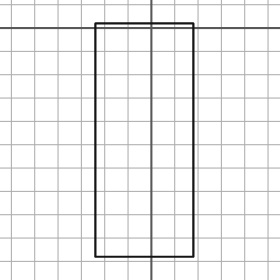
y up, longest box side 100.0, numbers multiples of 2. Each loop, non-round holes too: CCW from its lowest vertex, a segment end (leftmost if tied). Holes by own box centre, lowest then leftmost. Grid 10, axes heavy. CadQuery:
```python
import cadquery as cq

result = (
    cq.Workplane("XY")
    .moveTo(-24.0, -98.0)
    .lineTo(18.0, -98.0)
    .lineTo(18.0, 2.0)
    .lineTo(-24.0, 2.0)
    .close()
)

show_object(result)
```